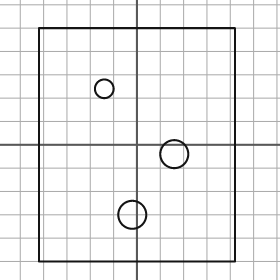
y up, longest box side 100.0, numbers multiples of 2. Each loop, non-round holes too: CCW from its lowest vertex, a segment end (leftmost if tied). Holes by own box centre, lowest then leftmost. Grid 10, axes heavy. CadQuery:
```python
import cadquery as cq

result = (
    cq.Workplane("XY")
    .moveTo(-42.0, -50.0)
    .lineTo(42.0, -50.0)
    .lineTo(42.0, 50.0)
    .lineTo(-42.0, 50.0)
    .close()
    .moveTo(-2.0, -30.0)
    .circle(6.0)
    .moveTo(16.0, -4.0)
    .circle(6.0)
    .moveTo(-14.0, 24.0)
    .circle(4.0)
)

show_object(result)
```